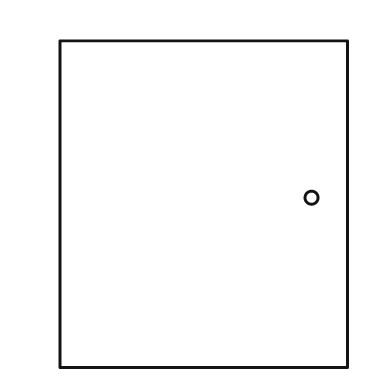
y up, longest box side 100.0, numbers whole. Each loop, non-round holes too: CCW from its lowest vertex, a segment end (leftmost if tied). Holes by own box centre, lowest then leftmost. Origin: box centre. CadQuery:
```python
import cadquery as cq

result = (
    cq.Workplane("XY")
    .moveTo(-44.0, -50.0)
    .lineTo(44.0, -50.0)
    .lineTo(44.0, 50.0)
    .lineTo(-44.0, 50.0)
    .close()
    .moveTo(33.0, 2.0)
    .circle(2.0)
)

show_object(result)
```